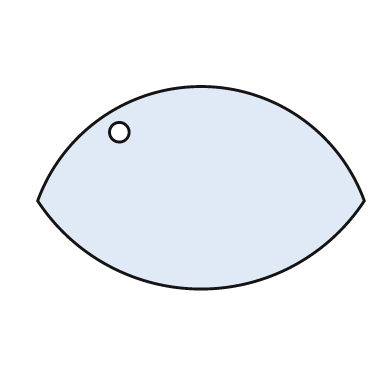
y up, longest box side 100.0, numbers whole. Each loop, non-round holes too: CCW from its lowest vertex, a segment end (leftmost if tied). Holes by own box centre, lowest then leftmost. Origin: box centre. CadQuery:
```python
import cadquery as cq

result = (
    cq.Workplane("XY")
    .moveTo(-50.0, -4.0)
    .threePointArc((0.0, -31.0), (50.0, -4.0))
    .threePointArc((0.0, 31.0), (-50.0, -4.0))
    .close()
    .moveTo(-25.0, 17.0)
    .circle(3.0)
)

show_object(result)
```